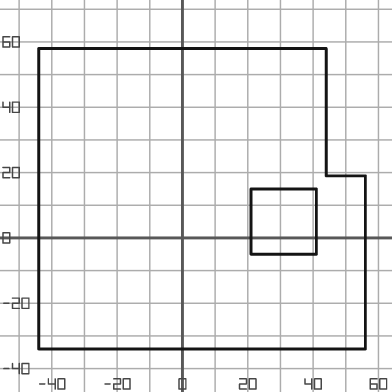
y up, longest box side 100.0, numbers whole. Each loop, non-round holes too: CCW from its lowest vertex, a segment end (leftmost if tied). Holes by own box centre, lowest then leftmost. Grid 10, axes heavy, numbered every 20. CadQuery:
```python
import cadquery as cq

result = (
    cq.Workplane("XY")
    .moveTo(-44.0, -34.0)
    .lineTo(56.0, -34.0)
    .lineTo(56.0, 19.0)
    .lineTo(44.0, 19.0)
    .lineTo(44.0, 58.0)
    .lineTo(-44.0, 58.0)
    .close()
    .moveTo(21.0, -5.0)
    .lineTo(41.0, -5.0)
    .lineTo(41.0, 15.0)
    .lineTo(21.0, 15.0)
    .close()
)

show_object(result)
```